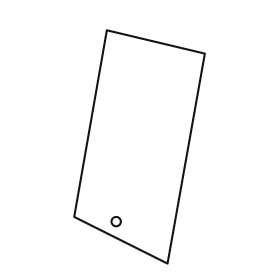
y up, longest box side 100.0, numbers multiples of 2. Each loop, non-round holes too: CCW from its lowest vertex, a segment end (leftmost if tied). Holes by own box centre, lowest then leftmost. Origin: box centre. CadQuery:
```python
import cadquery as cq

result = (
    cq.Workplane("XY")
    .moveTo(12.0, -50.0)
    .lineTo(28.0, 40.0)
    .lineTo(-14.0, 50.0)
    .lineTo(-28.0, -30.0)
    .close()
    .moveTo(-10.0, -32.0)
    .circle(2.0)
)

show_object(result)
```